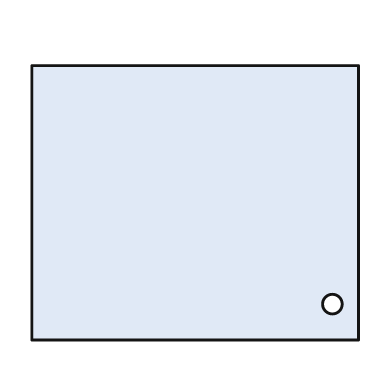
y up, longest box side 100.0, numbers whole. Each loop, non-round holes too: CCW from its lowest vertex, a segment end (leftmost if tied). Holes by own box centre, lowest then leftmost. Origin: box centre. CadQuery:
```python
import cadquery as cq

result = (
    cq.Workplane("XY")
    .moveTo(-50.0, -42.0)
    .lineTo(50.0, -42.0)
    .lineTo(50.0, 42.0)
    .lineTo(-50.0, 42.0)
    .close()
    .moveTo(42.0, -31.0)
    .circle(3.0)
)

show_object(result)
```